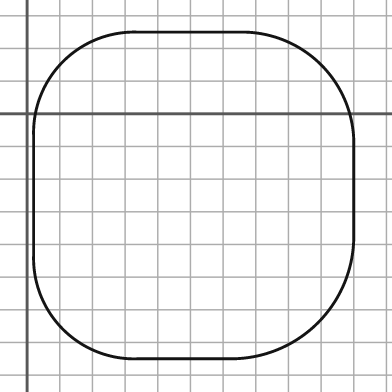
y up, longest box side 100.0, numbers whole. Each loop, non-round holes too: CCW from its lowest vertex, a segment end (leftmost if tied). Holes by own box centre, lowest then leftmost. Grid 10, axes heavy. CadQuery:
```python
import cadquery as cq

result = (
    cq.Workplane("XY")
    .moveTo(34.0, -75.0)
    .lineTo(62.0, -75.0)
    .threePointArc((89.0, -64.0), (100.0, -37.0))
    .lineTo(100.0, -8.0)
    .threePointArc((90.0, 15.0), (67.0, 25.0))
    .lineTo(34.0, 25.0)
    .threePointArc((11.0, 16.0), (2.0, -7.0))
    .lineTo(2.0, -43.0)
    .threePointArc((11.0, -66.0), (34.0, -75.0))
    .close()
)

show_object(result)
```